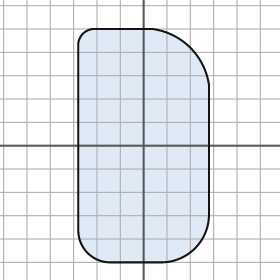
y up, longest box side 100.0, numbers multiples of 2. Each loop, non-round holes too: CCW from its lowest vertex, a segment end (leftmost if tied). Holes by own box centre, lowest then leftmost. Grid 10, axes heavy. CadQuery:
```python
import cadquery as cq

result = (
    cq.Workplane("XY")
    .moveTo(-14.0, -50.0)
    .lineTo(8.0, -50.0)
    .threePointArc((22.0, -44.0), (28.0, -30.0))
    .lineTo(28.0, 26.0)
    .threePointArc((20.0, 42.0), (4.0, 50.0))
    .lineTo(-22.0, 50.0)
    .threePointArc((-26.0, 48.0), (-28.0, 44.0))
    .lineTo(-28.0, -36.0)
    .threePointArc((-24.0, -46.0), (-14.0, -50.0))
    .close()
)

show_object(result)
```